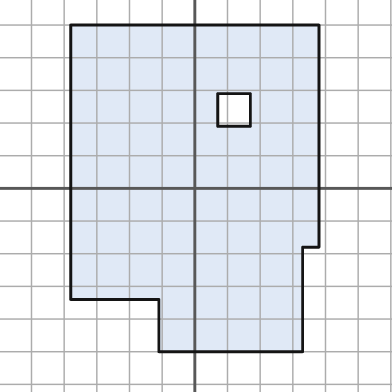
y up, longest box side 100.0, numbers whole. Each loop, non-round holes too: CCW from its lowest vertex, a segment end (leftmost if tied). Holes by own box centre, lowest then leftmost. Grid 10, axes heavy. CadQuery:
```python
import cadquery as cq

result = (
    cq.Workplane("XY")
    .moveTo(-11.0, -50.0)
    .lineTo(33.0, -50.0)
    .lineTo(33.0, -18.0)
    .lineTo(38.0, -18.0)
    .lineTo(38.0, 50.0)
    .lineTo(-38.0, 50.0)
    .lineTo(-38.0, -34.0)
    .lineTo(-11.0, -34.0)
    .close()
    .moveTo(7.0, 19.0)
    .lineTo(17.0, 19.0)
    .lineTo(17.0, 29.0)
    .lineTo(7.0, 29.0)
    .close()
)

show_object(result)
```